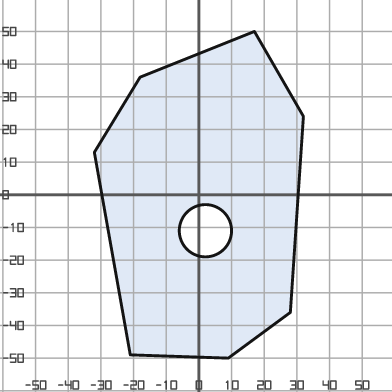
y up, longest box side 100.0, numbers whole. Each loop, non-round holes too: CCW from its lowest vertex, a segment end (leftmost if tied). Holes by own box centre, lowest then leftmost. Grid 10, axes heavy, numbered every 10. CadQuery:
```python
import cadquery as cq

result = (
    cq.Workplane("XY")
    .moveTo(9.0, -50.0)
    .lineTo(28.0, -36.0)
    .lineTo(32.0, 24.0)
    .lineTo(17.0, 50.0)
    .lineTo(-18.0, 36.0)
    .lineTo(-32.0, 13.0)
    .lineTo(-21.0, -49.0)
    .close()
    .moveTo(2.0, -11.0)
    .circle(8.0)
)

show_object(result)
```